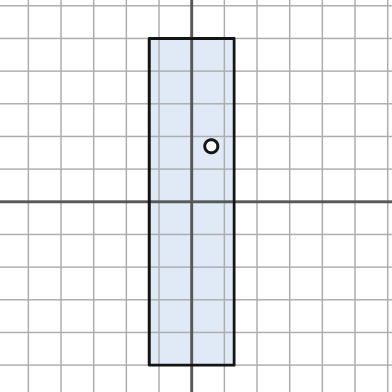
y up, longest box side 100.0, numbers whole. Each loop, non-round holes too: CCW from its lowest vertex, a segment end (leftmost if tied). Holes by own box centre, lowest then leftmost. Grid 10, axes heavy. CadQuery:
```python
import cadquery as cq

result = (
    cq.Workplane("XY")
    .moveTo(-13.0, -50.0)
    .lineTo(13.0, -50.0)
    .lineTo(13.0, 50.0)
    .lineTo(-13.0, 50.0)
    .close()
    .moveTo(6.0, 17.0)
    .circle(2.0)
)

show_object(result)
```